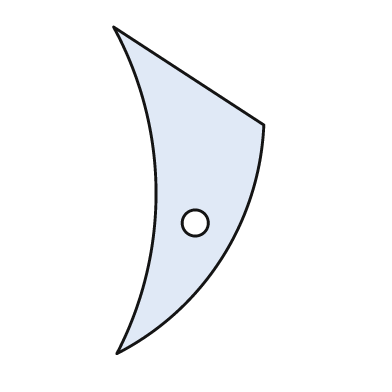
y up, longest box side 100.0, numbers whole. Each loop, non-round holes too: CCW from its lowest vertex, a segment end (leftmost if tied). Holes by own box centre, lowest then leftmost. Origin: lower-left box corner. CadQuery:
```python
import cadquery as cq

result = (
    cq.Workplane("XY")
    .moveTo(1.0, 0.0)
    .threePointArc((33.0, 29.0), (46.0, 70.0))
    .lineTo(0.0, 100.0)
    .threePointArc((13.0, 50.0), (1.0, 0.0))
    .close()
    .moveTo(25.0, 40.0)
    .circle(4.0)
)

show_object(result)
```